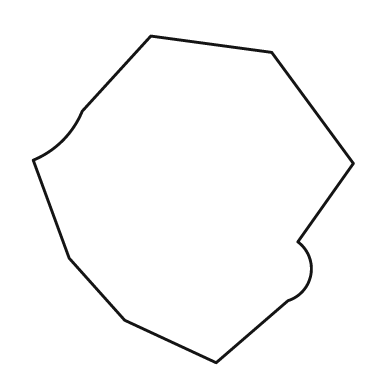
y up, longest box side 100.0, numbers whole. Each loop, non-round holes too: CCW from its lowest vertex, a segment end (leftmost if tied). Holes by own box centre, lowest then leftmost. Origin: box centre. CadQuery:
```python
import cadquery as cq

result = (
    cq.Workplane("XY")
    .moveTo(7.0, -50.0)
    .lineTo(29.0, -31.0)
    .threePointArc((36.0, -23.0), (32.0, -13.0))
    .lineTo(49.0, 11.0)
    .lineTo(24.0, 45.0)
    .lineTo(-13.0, 50.0)
    .lineTo(-34.0, 27.0)
    .threePointArc((-40.0, 18.0), (-49.0, 12.0))
    .lineTo(-38.0, -18.0)
    .lineTo(-21.0, -37.0)
    .close()
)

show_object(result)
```